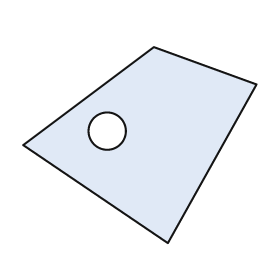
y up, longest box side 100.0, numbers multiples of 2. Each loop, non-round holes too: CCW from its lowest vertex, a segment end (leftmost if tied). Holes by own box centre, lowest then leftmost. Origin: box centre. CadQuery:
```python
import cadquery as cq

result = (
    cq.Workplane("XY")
    .moveTo(12.0, -42.0)
    .lineTo(50.0, 26.0)
    .lineTo(6.0, 42.0)
    .lineTo(-50.0, 0.0)
    .close()
    .moveTo(-14.0, 6.0)
    .circle(8.0)
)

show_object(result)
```